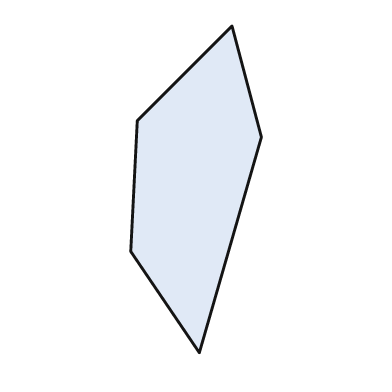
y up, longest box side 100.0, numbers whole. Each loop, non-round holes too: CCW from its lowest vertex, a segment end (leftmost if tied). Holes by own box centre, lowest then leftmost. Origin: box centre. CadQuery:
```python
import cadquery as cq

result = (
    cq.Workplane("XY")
    .moveTo(1.0, -50.0)
    .lineTo(20.0, 16.0)
    .lineTo(11.0, 50.0)
    .lineTo(-18.0, 21.0)
    .lineTo(-20.0, -19.0)
    .close()
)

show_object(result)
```